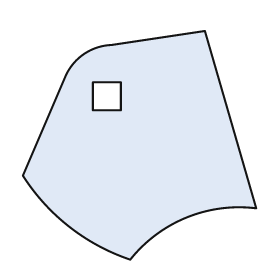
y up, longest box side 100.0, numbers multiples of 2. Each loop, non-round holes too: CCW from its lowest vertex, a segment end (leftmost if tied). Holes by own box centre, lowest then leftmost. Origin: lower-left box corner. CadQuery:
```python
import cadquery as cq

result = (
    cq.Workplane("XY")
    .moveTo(46.0, 0.0)
    .threePointArc((70.0, 18.0), (100.0, 22.0))
    .lineTo(78.0, 98.0)
    .lineTo(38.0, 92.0)
    .threePointArc((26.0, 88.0), (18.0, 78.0))
    .lineTo(0.0, 36.0)
    .threePointArc((20.0, 14.0), (46.0, 0.0))
    .close()
    .moveTo(30.0, 64.0)
    .lineTo(42.0, 64.0)
    .lineTo(42.0, 76.0)
    .lineTo(30.0, 76.0)
    .close()
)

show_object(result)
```